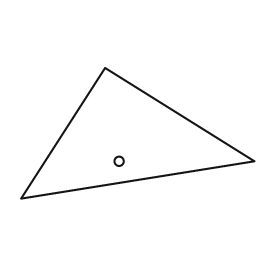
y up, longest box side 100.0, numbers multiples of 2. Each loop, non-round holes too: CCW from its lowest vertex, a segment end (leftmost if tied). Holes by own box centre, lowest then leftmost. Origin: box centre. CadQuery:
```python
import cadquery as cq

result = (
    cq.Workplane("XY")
    .moveTo(-50.0, -28.0)
    .lineTo(50.0, -12.0)
    .lineTo(-14.0, 28.0)
    .close()
    .moveTo(-8.0, -12.0)
    .circle(2.0)
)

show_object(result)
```